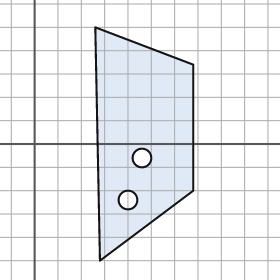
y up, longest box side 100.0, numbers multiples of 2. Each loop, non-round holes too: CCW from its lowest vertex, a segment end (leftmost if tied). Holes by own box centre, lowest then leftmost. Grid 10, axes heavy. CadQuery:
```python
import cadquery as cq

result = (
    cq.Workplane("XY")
    .moveTo(28.0, -50.0)
    .lineTo(68.0, -20.0)
    .lineTo(68.0, 34.0)
    .lineTo(26.0, 50.0)
    .close()
    .moveTo(40.0, -24.0)
    .circle(4.0)
    .moveTo(46.0, -6.0)
    .circle(4.0)
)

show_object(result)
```